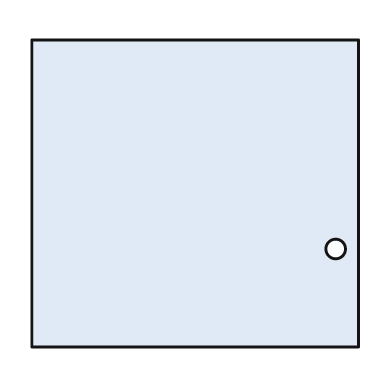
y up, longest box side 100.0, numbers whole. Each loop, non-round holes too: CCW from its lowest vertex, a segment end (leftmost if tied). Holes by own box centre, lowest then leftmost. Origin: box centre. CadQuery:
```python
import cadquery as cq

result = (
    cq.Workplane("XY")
    .moveTo(-50.0, -47.0)
    .lineTo(50.0, -47.0)
    .lineTo(50.0, 47.0)
    .lineTo(-50.0, 47.0)
    .close()
    .moveTo(43.0, -17.0)
    .circle(3.0)
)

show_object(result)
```